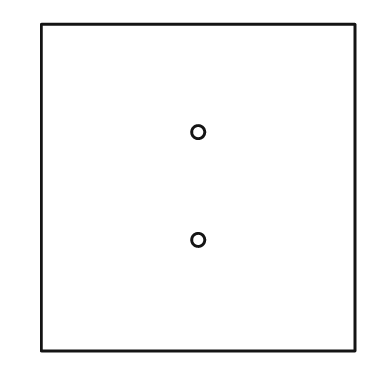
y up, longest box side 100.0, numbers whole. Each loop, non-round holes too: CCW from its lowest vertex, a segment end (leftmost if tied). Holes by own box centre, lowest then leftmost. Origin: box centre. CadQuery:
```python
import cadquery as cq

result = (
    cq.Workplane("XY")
    .moveTo(-48.0, -50.0)
    .lineTo(48.0, -50.0)
    .lineTo(48.0, 50.0)
    .lineTo(-48.0, 50.0)
    .close()
    .moveTo(0.0, -16.0)
    .circle(2.0)
    .moveTo(0.0, 17.0)
    .circle(2.0)
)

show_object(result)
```